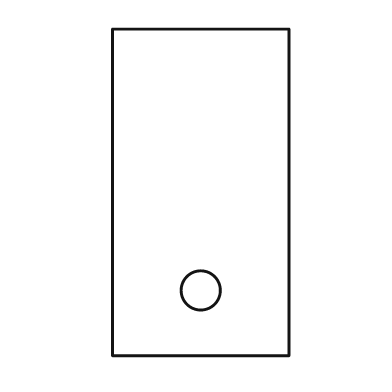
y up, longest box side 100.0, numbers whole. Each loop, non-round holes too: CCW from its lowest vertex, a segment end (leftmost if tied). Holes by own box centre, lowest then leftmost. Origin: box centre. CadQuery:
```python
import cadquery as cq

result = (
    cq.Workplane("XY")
    .moveTo(-27.0, -50.0)
    .lineTo(27.0, -50.0)
    .lineTo(27.0, 50.0)
    .lineTo(-27.0, 50.0)
    .close()
    .moveTo(0.0, -30.0)
    .circle(6.0)
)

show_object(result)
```